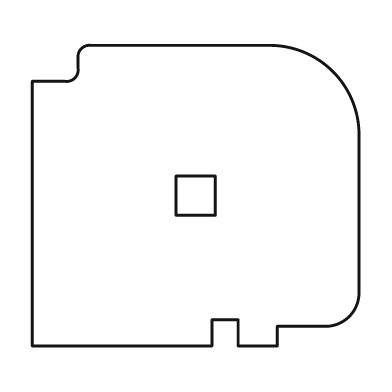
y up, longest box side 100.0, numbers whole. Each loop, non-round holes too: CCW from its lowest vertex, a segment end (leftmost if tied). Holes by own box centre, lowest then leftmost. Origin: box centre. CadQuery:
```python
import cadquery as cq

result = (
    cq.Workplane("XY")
    .moveTo(-50.0, -46.0)
    .lineTo(5.0, -46.0)
    .lineTo(5.0, -38.0)
    .lineTo(13.0, -38.0)
    .lineTo(13.0, -46.0)
    .lineTo(25.0, -46.0)
    .lineTo(25.0, -40.0)
    .lineTo(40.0, -40.0)
    .threePointArc((47.0, -37.0), (50.0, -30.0))
    .lineTo(50.0, 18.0)
    .threePointArc((42.0, 38.0), (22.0, 46.0))
    .lineTo(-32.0, 46.0)
    .threePointArc((-35.0, 45.0), (-36.0, 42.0))
    .lineTo(-36.0, 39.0)
    .threePointArc((-37.0, 36.0), (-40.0, 35.0))
    .lineTo(-50.0, 35.0)
    .close()
    .moveTo(-6.0, -6.0)
    .lineTo(6.0, -6.0)
    .lineTo(6.0, 6.0)
    .lineTo(-6.0, 6.0)
    .close()
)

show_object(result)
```